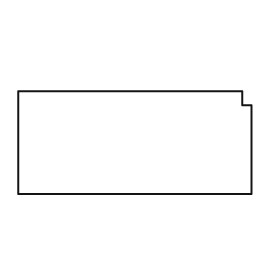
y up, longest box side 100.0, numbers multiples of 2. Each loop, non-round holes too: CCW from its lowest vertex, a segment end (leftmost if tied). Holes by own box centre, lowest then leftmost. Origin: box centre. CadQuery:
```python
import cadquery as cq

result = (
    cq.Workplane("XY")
    .moveTo(-50.0, -22.0)
    .lineTo(50.0, -22.0)
    .lineTo(50.0, 16.0)
    .lineTo(46.0, 16.0)
    .lineTo(46.0, 22.0)
    .lineTo(-50.0, 22.0)
    .close()
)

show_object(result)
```